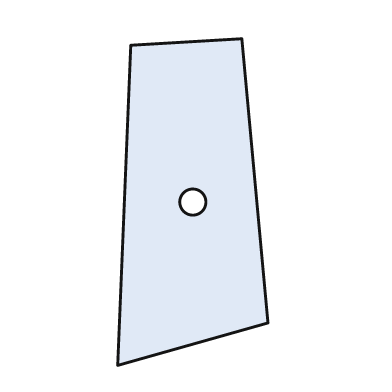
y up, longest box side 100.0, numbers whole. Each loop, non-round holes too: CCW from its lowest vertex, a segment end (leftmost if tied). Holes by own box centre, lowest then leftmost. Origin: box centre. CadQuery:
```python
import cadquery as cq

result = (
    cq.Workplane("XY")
    .moveTo(-23.0, -50.0)
    .lineTo(23.0, -37.0)
    .lineTo(15.0, 50.0)
    .lineTo(-19.0, 48.0)
    .close()
    .moveTo(0.0, 0.0)
    .circle(4.0)
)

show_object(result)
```